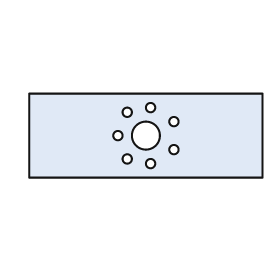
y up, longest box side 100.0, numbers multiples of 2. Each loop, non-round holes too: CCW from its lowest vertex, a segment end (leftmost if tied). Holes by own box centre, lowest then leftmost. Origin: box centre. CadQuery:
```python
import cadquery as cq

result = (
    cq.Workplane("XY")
    .moveTo(-50.0, -18.0)
    .lineTo(50.0, -18.0)
    .lineTo(50.0, 18.0)
    .lineTo(-50.0, 18.0)
    .close()
    .moveTo(2.0, -12.0)
    .circle(2.0)
    .moveTo(-8.0, -10.0)
    .circle(2.0)
    .moveTo(12.0, -6.0)
    .circle(2.0)
    .moveTo(-12.0, 0.0)
    .circle(2.0)
    .moveTo(0.0, 0.0)
    .circle(6.0)
    .moveTo(12.0, 6.0)
    .circle(2.0)
    .moveTo(-8.0, 10.0)
    .circle(2.0)
    .moveTo(2.0, 12.0)
    .circle(2.0)
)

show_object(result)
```